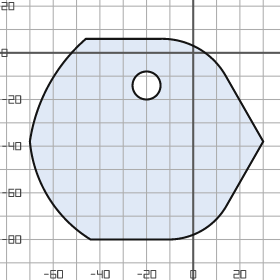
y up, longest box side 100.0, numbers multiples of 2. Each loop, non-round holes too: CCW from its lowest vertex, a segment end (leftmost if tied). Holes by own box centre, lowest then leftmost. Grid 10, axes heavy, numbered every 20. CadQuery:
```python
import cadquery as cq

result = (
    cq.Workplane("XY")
    .moveTo(-44.0, -80.0)
    .lineTo(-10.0, -80.0)
    .threePointArc((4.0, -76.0), (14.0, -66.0))
    .lineTo(30.0, -38.0)
    .lineTo(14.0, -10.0)
    .threePointArc((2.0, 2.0), (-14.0, 6.0))
    .lineTo(-46.0, 6.0)
    .threePointArc((-62.0, -14.0), (-70.0, -38.0))
    .threePointArc((-62.0, -62.0), (-44.0, -80.0))
    .close()
    .moveTo(-20.0, -14.0)
    .circle(6.0)
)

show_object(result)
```